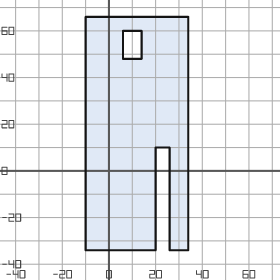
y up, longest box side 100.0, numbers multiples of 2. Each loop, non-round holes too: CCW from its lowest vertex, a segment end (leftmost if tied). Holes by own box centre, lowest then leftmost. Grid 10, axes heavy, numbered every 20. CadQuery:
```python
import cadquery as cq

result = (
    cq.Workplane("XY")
    .moveTo(-10.0, -34.0)
    .lineTo(20.0, -34.0)
    .lineTo(20.0, 10.0)
    .lineTo(26.0, 10.0)
    .lineTo(26.0, -34.0)
    .lineTo(34.0, -34.0)
    .lineTo(34.0, 66.0)
    .lineTo(-10.0, 66.0)
    .close()
    .moveTo(6.0, 48.0)
    .lineTo(14.0, 48.0)
    .lineTo(14.0, 60.0)
    .lineTo(6.0, 60.0)
    .close()
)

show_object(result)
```